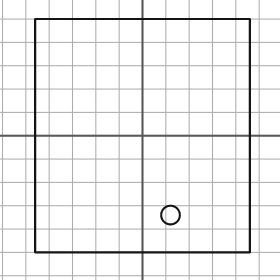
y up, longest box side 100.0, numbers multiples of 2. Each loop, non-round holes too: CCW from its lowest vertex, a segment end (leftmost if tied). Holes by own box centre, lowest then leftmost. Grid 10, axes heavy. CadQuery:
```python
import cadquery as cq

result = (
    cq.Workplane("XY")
    .moveTo(-46.0, -50.0)
    .lineTo(46.0, -50.0)
    .lineTo(46.0, 50.0)
    .lineTo(-46.0, 50.0)
    .close()
    .moveTo(12.0, -34.0)
    .circle(4.0)
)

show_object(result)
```